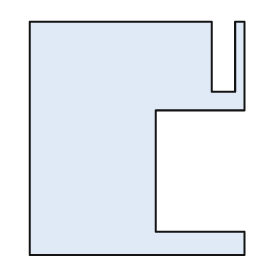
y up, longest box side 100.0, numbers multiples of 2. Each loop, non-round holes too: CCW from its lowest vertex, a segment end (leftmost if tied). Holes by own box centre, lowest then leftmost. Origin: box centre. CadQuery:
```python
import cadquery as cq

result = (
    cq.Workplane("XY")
    .moveTo(-46.0, -50.0)
    .lineTo(46.0, -50.0)
    .lineTo(46.0, -40.0)
    .lineTo(8.0, -40.0)
    .lineTo(8.0, 12.0)
    .lineTo(46.0, 12.0)
    .lineTo(46.0, 50.0)
    .lineTo(42.0, 50.0)
    .lineTo(42.0, 20.0)
    .lineTo(32.0, 20.0)
    .lineTo(32.0, 50.0)
    .lineTo(-46.0, 50.0)
    .close()
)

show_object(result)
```